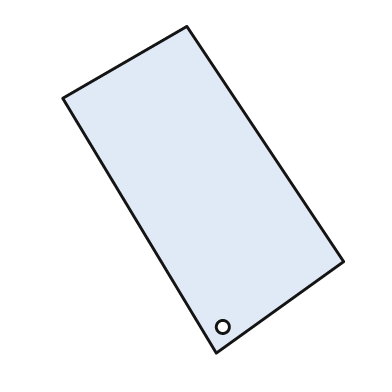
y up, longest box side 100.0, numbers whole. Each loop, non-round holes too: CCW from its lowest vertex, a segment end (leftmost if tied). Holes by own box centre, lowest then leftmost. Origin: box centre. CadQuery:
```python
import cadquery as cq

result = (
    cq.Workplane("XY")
    .moveTo(4.0, -50.0)
    .lineTo(43.0, -22.0)
    .lineTo(-5.0, 50.0)
    .lineTo(-43.0, 28.0)
    .close()
    .moveTo(6.0, -42.0)
    .circle(2.0)
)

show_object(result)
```